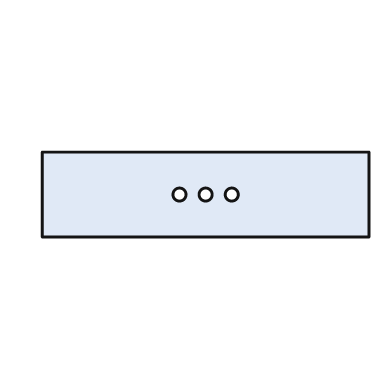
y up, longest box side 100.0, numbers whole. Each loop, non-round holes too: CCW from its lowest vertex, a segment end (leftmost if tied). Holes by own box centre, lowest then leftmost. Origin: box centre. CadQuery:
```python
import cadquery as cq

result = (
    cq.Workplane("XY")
    .moveTo(-50.0, -13.0)
    .lineTo(50.0, -13.0)
    .lineTo(50.0, 13.0)
    .lineTo(-50.0, 13.0)
    .close()
    .moveTo(-8.0, 0.0)
    .circle(2.0)
    .moveTo(0.0, 0.0)
    .circle(2.0)
    .moveTo(8.0, 0.0)
    .circle(2.0)
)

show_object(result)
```